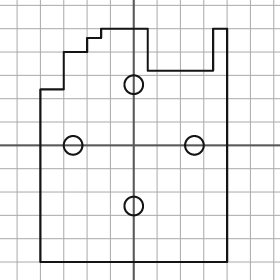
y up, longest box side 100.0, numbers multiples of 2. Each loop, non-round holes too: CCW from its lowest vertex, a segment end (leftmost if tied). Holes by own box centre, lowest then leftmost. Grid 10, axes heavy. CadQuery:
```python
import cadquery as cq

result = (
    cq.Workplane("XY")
    .moveTo(-40.0, -50.0)
    .lineTo(40.0, -50.0)
    .lineTo(40.0, 50.0)
    .lineTo(34.0, 50.0)
    .lineTo(34.0, 32.0)
    .lineTo(6.0, 32.0)
    .lineTo(6.0, 50.0)
    .lineTo(-14.0, 50.0)
    .lineTo(-14.0, 46.0)
    .lineTo(-20.0, 46.0)
    .lineTo(-20.0, 40.0)
    .lineTo(-30.0, 40.0)
    .lineTo(-30.0, 24.0)
    .lineTo(-40.0, 24.0)
    .close()
    .moveTo(0.0, -26.0)
    .circle(4.0)
    .moveTo(-26.0, 0.0)
    .circle(4.0)
    .moveTo(26.0, 0.0)
    .circle(4.0)
    .moveTo(0.0, 26.0)
    .circle(4.0)
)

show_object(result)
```